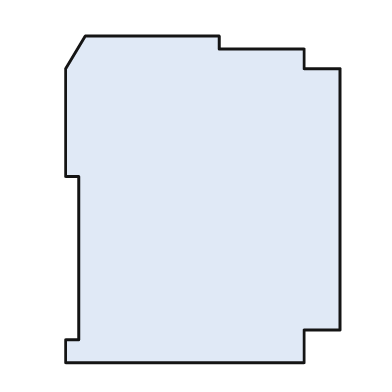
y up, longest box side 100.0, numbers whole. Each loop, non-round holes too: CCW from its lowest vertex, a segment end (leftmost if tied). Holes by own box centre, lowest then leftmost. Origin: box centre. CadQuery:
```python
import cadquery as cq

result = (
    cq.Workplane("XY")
    .moveTo(-42.0, -50.0)
    .lineTo(31.0, -50.0)
    .lineTo(31.0, -40.0)
    .lineTo(42.0, -40.0)
    .lineTo(42.0, 40.0)
    .lineTo(31.0, 40.0)
    .lineTo(31.0, 46.0)
    .lineTo(5.0, 46.0)
    .lineTo(5.0, 50.0)
    .lineTo(-36.0, 50.0)
    .lineTo(-42.0, 40.0)
    .lineTo(-42.0, 7.0)
    .lineTo(-38.0, 7.0)
    .lineTo(-38.0, -43.0)
    .lineTo(-42.0, -43.0)
    .close()
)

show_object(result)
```